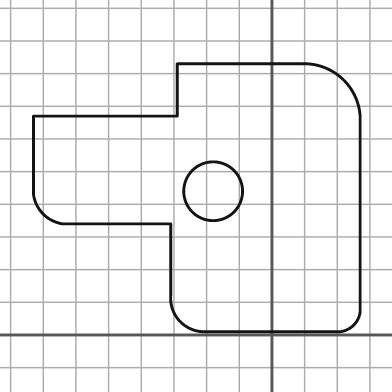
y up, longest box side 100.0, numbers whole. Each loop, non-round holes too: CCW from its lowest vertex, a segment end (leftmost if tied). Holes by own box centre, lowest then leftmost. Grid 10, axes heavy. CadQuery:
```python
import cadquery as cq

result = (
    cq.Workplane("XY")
    .moveTo(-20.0, 1.0)
    .lineTo(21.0, 1.0)
    .threePointArc((25.0, 3.0), (27.0, 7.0))
    .lineTo(27.0, 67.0)
    .threePointArc((22.0, 78.0), (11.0, 83.0))
    .lineTo(-29.0, 83.0)
    .lineTo(-29.0, 67.0)
    .lineTo(-73.0, 67.0)
    .lineTo(-73.0, 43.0)
    .threePointArc((-70.0, 37.0), (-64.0, 34.0))
    .lineTo(-31.0, 34.0)
    .lineTo(-31.0, 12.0)
    .threePointArc((-28.0, 4.0), (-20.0, 1.0))
    .close()
    .moveTo(-18.0, 44.0)
    .circle(9.0)
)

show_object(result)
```